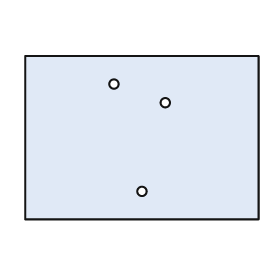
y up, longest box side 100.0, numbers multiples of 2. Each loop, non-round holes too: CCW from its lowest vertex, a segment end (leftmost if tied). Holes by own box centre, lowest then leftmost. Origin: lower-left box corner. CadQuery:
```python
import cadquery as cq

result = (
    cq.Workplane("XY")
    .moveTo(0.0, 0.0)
    .lineTo(100.0, 0.0)
    .lineTo(100.0, 70.0)
    .lineTo(0.0, 70.0)
    .close()
    .moveTo(50.0, 12.0)
    .circle(2.0)
    .moveTo(60.0, 50.0)
    .circle(2.0)
    .moveTo(38.0, 58.0)
    .circle(2.0)
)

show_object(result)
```